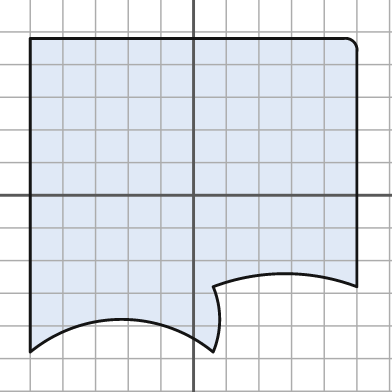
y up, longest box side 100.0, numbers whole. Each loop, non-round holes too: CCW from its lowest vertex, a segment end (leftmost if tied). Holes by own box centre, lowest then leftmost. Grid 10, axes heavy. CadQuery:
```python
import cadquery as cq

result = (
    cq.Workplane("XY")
    .moveTo(-50.0, -48.0)
    .threePointArc((-22.0, -38.0), (6.0, -48.0))
    .threePointArc((8.0, -38.0), (6.0, -28.0))
    .threePointArc((28.0, -24.0), (50.0, -28.0))
    .lineTo(50.0, 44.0)
    .threePointArc((49.0, 47.0), (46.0, 48.0))
    .lineTo(-50.0, 48.0)
    .close()
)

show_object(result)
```